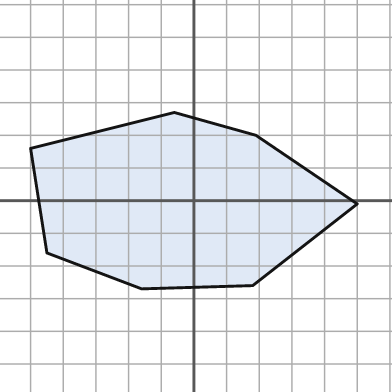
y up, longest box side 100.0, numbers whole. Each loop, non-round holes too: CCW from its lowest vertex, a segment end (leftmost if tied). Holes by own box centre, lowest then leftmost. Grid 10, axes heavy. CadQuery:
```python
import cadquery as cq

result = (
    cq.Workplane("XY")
    .moveTo(-16.0, -27.0)
    .lineTo(18.0, -26.0)
    .lineTo(50.0, -1.0)
    .lineTo(19.0, 20.0)
    .lineTo(-6.0, 27.0)
    .lineTo(-50.0, 16.0)
    .lineTo(-45.0, -16.0)
    .close()
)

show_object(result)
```